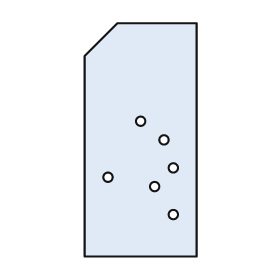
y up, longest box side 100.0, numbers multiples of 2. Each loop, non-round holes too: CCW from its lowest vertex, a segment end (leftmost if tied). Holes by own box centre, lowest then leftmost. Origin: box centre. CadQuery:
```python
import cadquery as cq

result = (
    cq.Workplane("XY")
    .moveTo(-24.0, -50.0)
    .lineTo(24.0, -50.0)
    .lineTo(24.0, 50.0)
    .lineTo(-10.0, 50.0)
    .lineTo(-24.0, 36.0)
    .close()
    .moveTo(14.0, -32.0)
    .circle(2.0)
    .moveTo(6.0, -20.0)
    .circle(2.0)
    .moveTo(-14.0, -16.0)
    .circle(2.0)
    .moveTo(14.0, -12.0)
    .circle(2.0)
    .moveTo(10.0, 0.0)
    .circle(2.0)
    .moveTo(0.0, 8.0)
    .circle(2.0)
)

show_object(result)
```